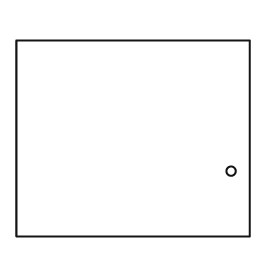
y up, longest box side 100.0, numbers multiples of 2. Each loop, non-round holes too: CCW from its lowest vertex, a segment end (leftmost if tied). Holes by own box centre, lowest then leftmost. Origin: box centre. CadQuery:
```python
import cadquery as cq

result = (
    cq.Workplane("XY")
    .moveTo(-50.0, -42.0)
    .lineTo(50.0, -42.0)
    .lineTo(50.0, 42.0)
    .lineTo(-50.0, 42.0)
    .close()
    .moveTo(42.0, -14.0)
    .circle(2.0)
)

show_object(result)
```